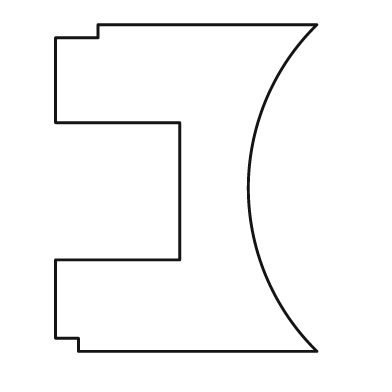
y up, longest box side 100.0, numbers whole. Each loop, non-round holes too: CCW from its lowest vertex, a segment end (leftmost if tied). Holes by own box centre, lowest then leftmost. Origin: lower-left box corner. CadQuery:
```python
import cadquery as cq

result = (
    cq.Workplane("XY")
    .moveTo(7.0, 0.0)
    .lineTo(80.0, 0.0)
    .threePointArc((59.0, 50.0), (80.0, 100.0))
    .lineTo(13.0, 100.0)
    .lineTo(13.0, 96.0)
    .lineTo(0.0, 96.0)
    .lineTo(0.0, 70.0)
    .lineTo(38.0, 70.0)
    .lineTo(38.0, 28.0)
    .lineTo(0.0, 28.0)
    .lineTo(0.0, 4.0)
    .lineTo(7.0, 4.0)
    .close()
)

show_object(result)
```